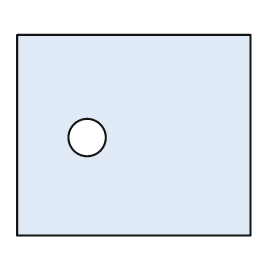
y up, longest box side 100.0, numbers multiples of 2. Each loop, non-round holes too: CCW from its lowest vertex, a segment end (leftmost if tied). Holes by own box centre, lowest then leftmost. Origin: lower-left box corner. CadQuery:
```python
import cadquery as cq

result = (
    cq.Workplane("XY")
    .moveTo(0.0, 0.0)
    .lineTo(100.0, 0.0)
    .lineTo(100.0, 86.0)
    .lineTo(0.0, 86.0)
    .close()
    .moveTo(30.0, 42.0)
    .circle(8.0)
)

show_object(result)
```